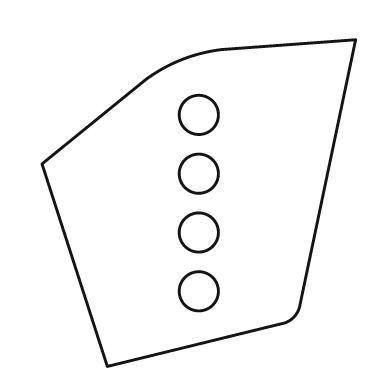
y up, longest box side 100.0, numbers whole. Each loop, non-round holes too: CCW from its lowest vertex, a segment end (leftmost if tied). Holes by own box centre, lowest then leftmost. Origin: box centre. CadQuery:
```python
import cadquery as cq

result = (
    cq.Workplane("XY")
    .moveTo(-28.0, -50.0)
    .lineTo(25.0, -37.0)
    .threePointArc((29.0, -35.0), (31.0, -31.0))
    .lineTo(48.0, 50.0)
    .lineTo(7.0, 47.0)
    .threePointArc((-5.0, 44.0), (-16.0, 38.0))
    .lineTo(-48.0, 12.0)
    .close()
    .moveTo(0.0, -27.0)
    .circle(6.0)
    .moveTo(0.0, -9.0)
    .circle(6.0)
    .moveTo(0.0, 9.0)
    .circle(6.0)
    .moveTo(0.0, 27.0)
    .circle(6.0)
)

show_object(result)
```